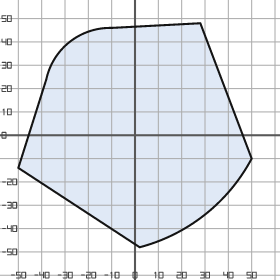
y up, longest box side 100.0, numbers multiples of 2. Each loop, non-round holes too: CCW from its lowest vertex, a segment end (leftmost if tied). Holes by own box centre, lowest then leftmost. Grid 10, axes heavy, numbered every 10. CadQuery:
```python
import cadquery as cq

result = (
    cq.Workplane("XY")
    .moveTo(2.0, -48.0)
    .threePointArc((30.0, -34.0), (50.0, -10.0))
    .lineTo(28.0, 48.0)
    .lineTo(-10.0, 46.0)
    .threePointArc((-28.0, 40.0), (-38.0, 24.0))
    .lineTo(-50.0, -14.0)
    .close()
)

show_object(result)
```